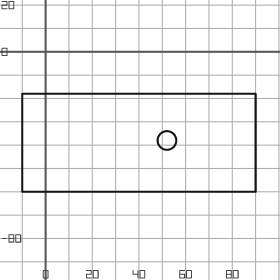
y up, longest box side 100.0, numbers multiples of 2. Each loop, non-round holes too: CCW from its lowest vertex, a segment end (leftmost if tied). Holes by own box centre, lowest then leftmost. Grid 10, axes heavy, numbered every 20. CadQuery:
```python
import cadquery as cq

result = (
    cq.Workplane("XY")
    .moveTo(-10.0, -60.0)
    .lineTo(90.0, -60.0)
    .lineTo(90.0, -18.0)
    .lineTo(-10.0, -18.0)
    .close()
    .moveTo(52.0, -38.0)
    .circle(4.0)
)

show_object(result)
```